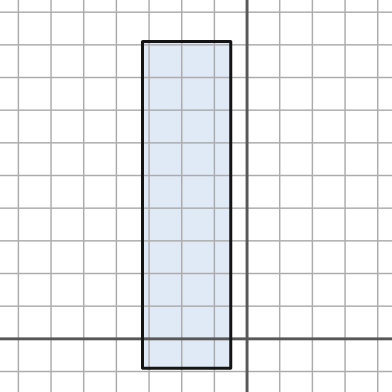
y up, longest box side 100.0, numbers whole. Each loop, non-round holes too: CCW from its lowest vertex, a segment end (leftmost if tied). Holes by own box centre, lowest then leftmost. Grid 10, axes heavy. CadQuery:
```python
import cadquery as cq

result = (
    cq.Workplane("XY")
    .moveTo(-32.0, -9.0)
    .lineTo(-5.0, -9.0)
    .lineTo(-5.0, 91.0)
    .lineTo(-32.0, 91.0)
    .close()
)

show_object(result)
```